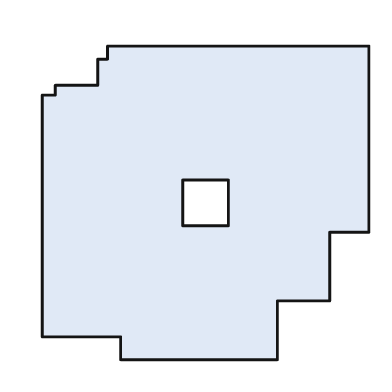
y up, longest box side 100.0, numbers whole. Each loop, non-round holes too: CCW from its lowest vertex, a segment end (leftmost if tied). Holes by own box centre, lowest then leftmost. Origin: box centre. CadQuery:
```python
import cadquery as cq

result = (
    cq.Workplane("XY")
    .moveTo(-26.0, -48.0)
    .lineTo(22.0, -48.0)
    .lineTo(22.0, -30.0)
    .lineTo(38.0, -30.0)
    .lineTo(38.0, -9.0)
    .lineTo(50.0, -9.0)
    .lineTo(50.0, 48.0)
    .lineTo(-30.0, 48.0)
    .lineTo(-30.0, 44.0)
    .lineTo(-33.0, 44.0)
    .lineTo(-33.0, 36.0)
    .lineTo(-46.0, 36.0)
    .lineTo(-46.0, 33.0)
    .lineTo(-50.0, 33.0)
    .lineTo(-50.0, -41.0)
    .lineTo(-26.0, -41.0)
    .close()
    .moveTo(-7.0, -7.0)
    .lineTo(7.0, -7.0)
    .lineTo(7.0, 7.0)
    .lineTo(-7.0, 7.0)
    .close()
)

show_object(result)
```